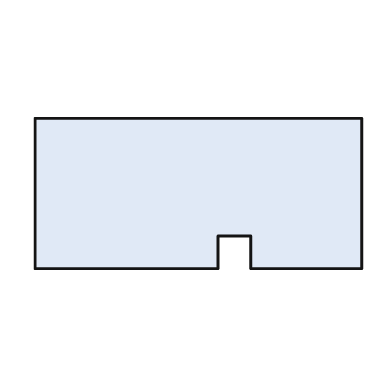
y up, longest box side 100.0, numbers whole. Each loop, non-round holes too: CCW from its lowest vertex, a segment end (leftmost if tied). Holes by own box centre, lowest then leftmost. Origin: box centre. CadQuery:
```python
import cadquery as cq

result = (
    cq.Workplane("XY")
    .moveTo(-50.0, -23.0)
    .lineTo(6.0, -23.0)
    .lineTo(6.0, -13.0)
    .lineTo(16.0, -13.0)
    .lineTo(16.0, -23.0)
    .lineTo(50.0, -23.0)
    .lineTo(50.0, 23.0)
    .lineTo(-50.0, 23.0)
    .close()
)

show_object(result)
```